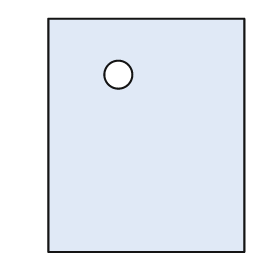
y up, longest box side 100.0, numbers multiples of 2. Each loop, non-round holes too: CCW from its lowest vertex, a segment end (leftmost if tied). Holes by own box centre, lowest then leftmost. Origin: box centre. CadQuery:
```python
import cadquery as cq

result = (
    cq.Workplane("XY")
    .moveTo(-42.0, -50.0)
    .lineTo(42.0, -50.0)
    .lineTo(42.0, 50.0)
    .lineTo(-42.0, 50.0)
    .close()
    .moveTo(-12.0, 26.0)
    .circle(6.0)
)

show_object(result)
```